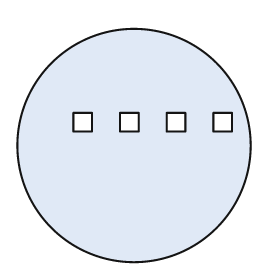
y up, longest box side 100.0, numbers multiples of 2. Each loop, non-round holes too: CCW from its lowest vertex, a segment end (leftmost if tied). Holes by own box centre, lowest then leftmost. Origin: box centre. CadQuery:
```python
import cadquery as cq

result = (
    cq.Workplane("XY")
    .moveTo(0.0, 0.0)
    .circle(50.0)
    .moveTo(-26.0, 6.0)
    .lineTo(-18.0, 6.0)
    .lineTo(-18.0, 14.0)
    .lineTo(-26.0, 14.0)
    .close()
    .moveTo(-6.0, 6.0)
    .lineTo(2.0, 6.0)
    .lineTo(2.0, 14.0)
    .lineTo(-6.0, 14.0)
    .close()
    .moveTo(14.0, 6.0)
    .lineTo(22.0, 6.0)
    .lineTo(22.0, 14.0)
    .lineTo(14.0, 14.0)
    .close()
    .moveTo(34.0, 6.0)
    .lineTo(42.0, 6.0)
    .lineTo(42.0, 14.0)
    .lineTo(34.0, 14.0)
    .close()
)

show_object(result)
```